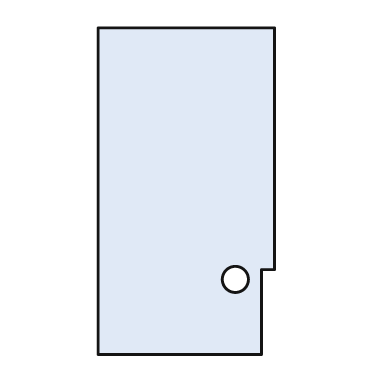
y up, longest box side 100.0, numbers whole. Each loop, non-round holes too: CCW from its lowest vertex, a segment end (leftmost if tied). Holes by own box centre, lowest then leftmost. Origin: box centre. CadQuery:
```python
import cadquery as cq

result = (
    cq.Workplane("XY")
    .moveTo(-27.0, -50.0)
    .lineTo(23.0, -50.0)
    .lineTo(23.0, -24.0)
    .lineTo(27.0, -24.0)
    .lineTo(27.0, 50.0)
    .lineTo(-27.0, 50.0)
    .close()
    .moveTo(15.0, -27.0)
    .circle(4.0)
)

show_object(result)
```